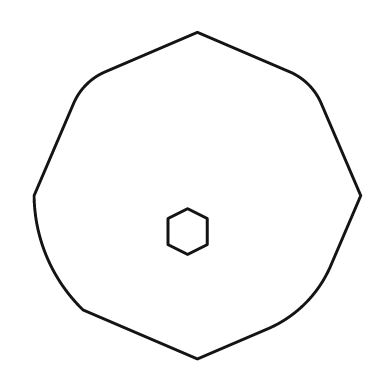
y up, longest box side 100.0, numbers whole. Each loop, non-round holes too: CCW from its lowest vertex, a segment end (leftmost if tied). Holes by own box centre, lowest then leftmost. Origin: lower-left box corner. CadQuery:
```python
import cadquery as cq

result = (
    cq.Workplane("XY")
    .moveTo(50.0, 0.0)
    .lineTo(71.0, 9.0)
    .threePointArc((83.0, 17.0), (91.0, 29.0))
    .lineTo(100.0, 50.0)
    .lineTo(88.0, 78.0)
    .threePointArc((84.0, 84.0), (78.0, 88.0))
    .lineTo(50.0, 100.0)
    .lineTo(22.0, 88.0)
    .threePointArc((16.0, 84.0), (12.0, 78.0))
    .lineTo(0.0, 50.0)
    .threePointArc((4.0, 31.0), (15.0, 15.0))
    .close()
    .moveTo(47.0, 32.0)
    .lineTo(53.0, 35.0)
    .lineTo(53.0, 43.0)
    .lineTo(47.0, 46.0)
    .lineTo(41.0, 43.0)
    .lineTo(41.0, 35.0)
    .close()
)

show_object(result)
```